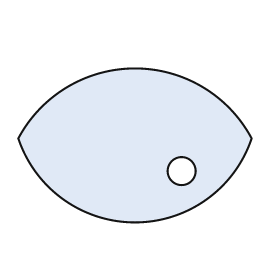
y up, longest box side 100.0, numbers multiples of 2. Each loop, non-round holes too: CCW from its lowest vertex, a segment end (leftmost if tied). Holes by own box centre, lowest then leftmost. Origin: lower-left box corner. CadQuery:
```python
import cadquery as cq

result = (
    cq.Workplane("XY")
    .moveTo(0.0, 36.0)
    .threePointArc((50.0, 0.0), (100.0, 36.0))
    .threePointArc((50.0, 66.0), (0.0, 36.0))
    .close()
    .moveTo(70.0, 22.0)
    .circle(6.0)
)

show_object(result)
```